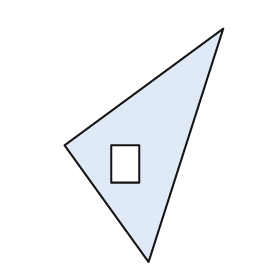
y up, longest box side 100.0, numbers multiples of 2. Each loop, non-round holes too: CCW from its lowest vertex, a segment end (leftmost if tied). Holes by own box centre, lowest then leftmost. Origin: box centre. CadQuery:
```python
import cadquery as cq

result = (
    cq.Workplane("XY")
    .moveTo(2.0, -50.0)
    .lineTo(34.0, 50.0)
    .lineTo(-34.0, 0.0)
    .close()
    .moveTo(-14.0, -16.0)
    .lineTo(-2.0, -16.0)
    .lineTo(-2.0, 0.0)
    .lineTo(-14.0, 0.0)
    .close()
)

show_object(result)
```